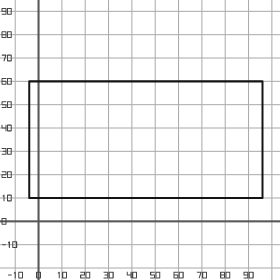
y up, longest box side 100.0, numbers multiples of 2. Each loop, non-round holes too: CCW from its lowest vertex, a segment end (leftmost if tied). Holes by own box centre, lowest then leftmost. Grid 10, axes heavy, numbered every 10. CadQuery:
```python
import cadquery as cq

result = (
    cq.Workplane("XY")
    .moveTo(-4.0, 10.0)
    .lineTo(96.0, 10.0)
    .lineTo(96.0, 60.0)
    .lineTo(-4.0, 60.0)
    .close()
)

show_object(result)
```